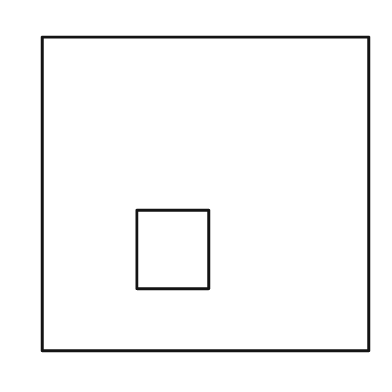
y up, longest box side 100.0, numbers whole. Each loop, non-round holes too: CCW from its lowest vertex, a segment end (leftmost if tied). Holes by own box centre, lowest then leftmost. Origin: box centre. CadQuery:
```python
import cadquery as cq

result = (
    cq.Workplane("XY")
    .moveTo(-50.0, -48.0)
    .lineTo(50.0, -48.0)
    .lineTo(50.0, 48.0)
    .lineTo(-50.0, 48.0)
    .close()
    .moveTo(-21.0, -29.0)
    .lineTo(1.0, -29.0)
    .lineTo(1.0, -5.0)
    .lineTo(-21.0, -5.0)
    .close()
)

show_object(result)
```